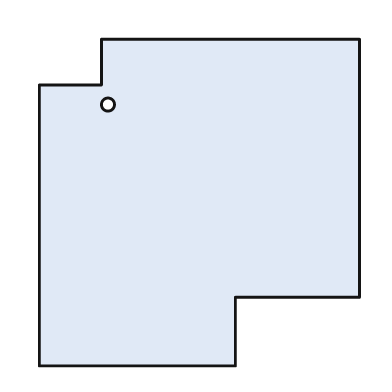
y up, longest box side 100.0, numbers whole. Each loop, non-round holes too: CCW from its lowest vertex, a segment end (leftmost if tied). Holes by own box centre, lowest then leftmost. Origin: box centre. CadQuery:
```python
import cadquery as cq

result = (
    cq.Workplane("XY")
    .moveTo(-49.0, -50.0)
    .lineTo(11.0, -50.0)
    .lineTo(11.0, -29.0)
    .lineTo(49.0, -29.0)
    .lineTo(49.0, 50.0)
    .lineTo(-30.0, 50.0)
    .lineTo(-30.0, 36.0)
    .lineTo(-49.0, 36.0)
    .close()
    .moveTo(-28.0, 30.0)
    .circle(2.0)
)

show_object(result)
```